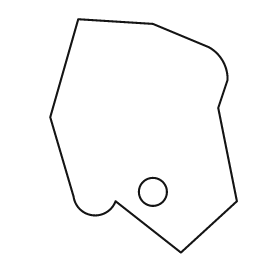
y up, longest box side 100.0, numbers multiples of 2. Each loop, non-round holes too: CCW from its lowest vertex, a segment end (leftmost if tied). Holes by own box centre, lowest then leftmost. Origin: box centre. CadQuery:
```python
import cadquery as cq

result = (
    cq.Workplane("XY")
    .moveTo(16.0, -50.0)
    .lineTo(40.0, -28.0)
    .lineTo(32.0, 12.0)
    .lineTo(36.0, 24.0)
    .threePointArc((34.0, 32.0), (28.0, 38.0))
    .lineTo(4.0, 48.0)
    .lineTo(-28.0, 50.0)
    .lineTo(-40.0, 8.0)
    .lineTo(-30.0, -26.0)
    .threePointArc((-22.0, -34.0), (-12.0, -28.0))
    .close()
    .moveTo(4.0, -24.0)
    .circle(6.0)
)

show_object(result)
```